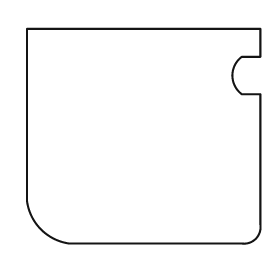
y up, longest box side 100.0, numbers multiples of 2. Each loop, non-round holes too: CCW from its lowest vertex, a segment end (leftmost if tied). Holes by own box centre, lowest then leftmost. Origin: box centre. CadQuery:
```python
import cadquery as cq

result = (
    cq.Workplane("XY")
    .moveTo(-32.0, -46.0)
    .lineTo(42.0, -46.0)
    .threePointArc((48.0, -44.0), (50.0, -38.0))
    .lineTo(50.0, 18.0)
    .lineTo(42.0, 18.0)
    .threePointArc((38.0, 26.0), (42.0, 34.0))
    .lineTo(50.0, 34.0)
    .lineTo(50.0, 46.0)
    .lineTo(-50.0, 46.0)
    .lineTo(-50.0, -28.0)
    .threePointArc((-44.0, -40.0), (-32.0, -46.0))
    .close()
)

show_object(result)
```